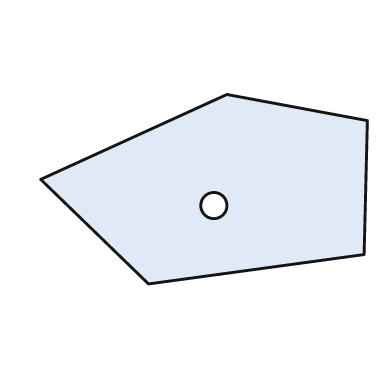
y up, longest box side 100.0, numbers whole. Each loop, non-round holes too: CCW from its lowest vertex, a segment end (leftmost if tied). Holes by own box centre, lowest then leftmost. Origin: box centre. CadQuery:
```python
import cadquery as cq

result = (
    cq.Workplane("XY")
    .moveTo(-17.0, -29.0)
    .lineTo(49.0, -20.0)
    .lineTo(50.0, 21.0)
    .lineTo(7.0, 29.0)
    .lineTo(-50.0, 3.0)
    .close()
    .moveTo(3.0, -5.0)
    .circle(4.0)
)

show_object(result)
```